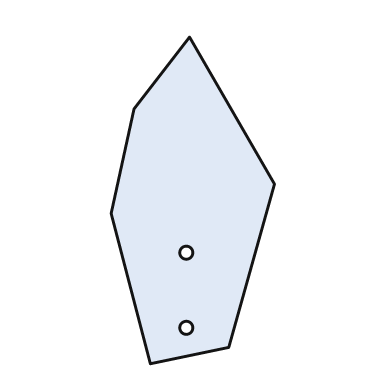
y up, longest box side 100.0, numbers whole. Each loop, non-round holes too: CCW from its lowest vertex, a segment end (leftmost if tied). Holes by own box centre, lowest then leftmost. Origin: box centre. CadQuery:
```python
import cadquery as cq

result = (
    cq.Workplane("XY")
    .moveTo(-13.0, -50.0)
    .lineTo(11.0, -45.0)
    .lineTo(25.0, 5.0)
    .lineTo(-1.0, 50.0)
    .lineTo(-18.0, 28.0)
    .lineTo(-25.0, -4.0)
    .close()
    .moveTo(-2.0, -39.0)
    .circle(2.0)
    .moveTo(-2.0, -16.0)
    .circle(2.0)
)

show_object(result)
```